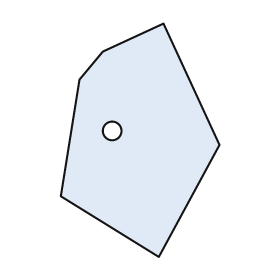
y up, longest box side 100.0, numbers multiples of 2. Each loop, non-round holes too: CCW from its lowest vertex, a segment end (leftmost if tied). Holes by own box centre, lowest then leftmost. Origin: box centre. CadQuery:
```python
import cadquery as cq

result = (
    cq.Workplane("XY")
    .moveTo(8.0, -50.0)
    .lineTo(34.0, -2.0)
    .lineTo(10.0, 50.0)
    .lineTo(-16.0, 38.0)
    .lineTo(-26.0, 26.0)
    .lineTo(-34.0, -24.0)
    .close()
    .moveTo(-12.0, 4.0)
    .circle(4.0)
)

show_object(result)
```